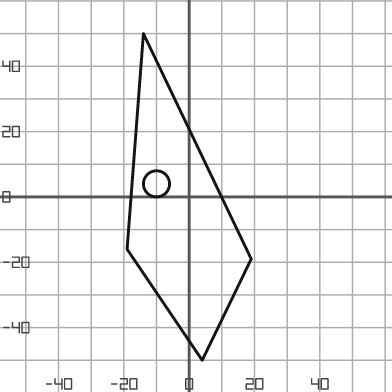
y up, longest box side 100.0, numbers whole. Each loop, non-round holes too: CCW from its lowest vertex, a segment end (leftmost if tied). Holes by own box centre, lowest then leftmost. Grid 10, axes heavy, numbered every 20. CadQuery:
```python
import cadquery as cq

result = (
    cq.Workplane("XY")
    .moveTo(4.0, -50.0)
    .lineTo(19.0, -19.0)
    .lineTo(-14.0, 50.0)
    .lineTo(-19.0, -16.0)
    .close()
    .moveTo(-10.0, 4.0)
    .circle(4.0)
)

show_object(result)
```